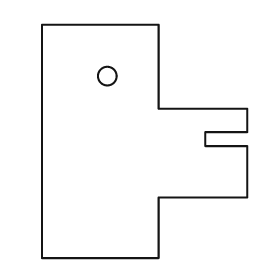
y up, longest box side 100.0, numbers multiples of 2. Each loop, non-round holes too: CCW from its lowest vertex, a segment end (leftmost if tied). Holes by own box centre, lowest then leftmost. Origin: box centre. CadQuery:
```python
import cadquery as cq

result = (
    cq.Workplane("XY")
    .moveTo(-44.0, -50.0)
    .lineTo(6.0, -50.0)
    .lineTo(6.0, -24.0)
    .lineTo(44.0, -24.0)
    .lineTo(44.0, -2.0)
    .lineTo(26.0, -2.0)
    .lineTo(26.0, 4.0)
    .lineTo(44.0, 4.0)
    .lineTo(44.0, 14.0)
    .lineTo(6.0, 14.0)
    .lineTo(6.0, 50.0)
    .lineTo(-44.0, 50.0)
    .close()
    .moveTo(-16.0, 28.0)
    .circle(4.0)
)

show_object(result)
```